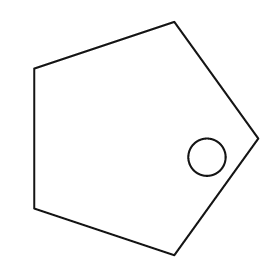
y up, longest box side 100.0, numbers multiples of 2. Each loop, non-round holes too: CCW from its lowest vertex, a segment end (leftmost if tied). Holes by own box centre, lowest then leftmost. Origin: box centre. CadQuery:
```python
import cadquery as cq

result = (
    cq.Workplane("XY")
    .moveTo(12.0, -50.0)
    .lineTo(48.0, 0.0)
    .lineTo(12.0, 50.0)
    .lineTo(-48.0, 30.0)
    .lineTo(-48.0, -30.0)
    .close()
    .moveTo(26.0, -8.0)
    .circle(8.0)
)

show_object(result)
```